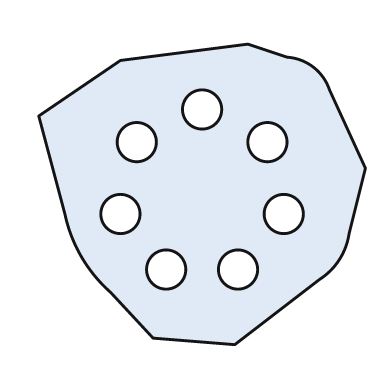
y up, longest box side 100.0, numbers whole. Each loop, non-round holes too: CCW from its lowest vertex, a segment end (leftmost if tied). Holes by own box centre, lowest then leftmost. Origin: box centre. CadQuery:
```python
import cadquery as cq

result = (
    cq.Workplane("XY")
    .moveTo(10.0, -46.0)
    .lineTo(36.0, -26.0)
    .threePointArc((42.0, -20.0), (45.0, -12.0))
    .lineTo(50.0, 8.0)
    .lineTo(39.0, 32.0)
    .threePointArc((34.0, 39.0), (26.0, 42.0))
    .lineTo(14.0, 46.0)
    .lineTo(-25.0, 41.0)
    .lineTo(-50.0, 24.0)
    .lineTo(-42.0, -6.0)
    .threePointArc((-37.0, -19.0), (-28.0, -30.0))
    .lineTo(-15.0, -44.0)
    .close()
    .moveTo(-11.0, -23.0)
    .circle(6.0)
    .moveTo(11.0, -23.0)
    .circle(6.0)
    .moveTo(-25.0, -6.0)
    .circle(6.0)
    .moveTo(25.0, -6.0)
    .circle(6.0)
    .moveTo(-20.0, 16.0)
    .circle(6.0)
    .moveTo(20.0, 16.0)
    .circle(6.0)
    .moveTo(0.0, 26.0)
    .circle(6.0)
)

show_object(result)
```